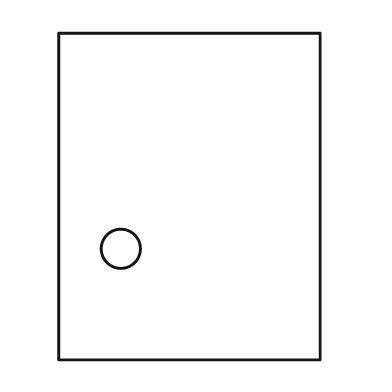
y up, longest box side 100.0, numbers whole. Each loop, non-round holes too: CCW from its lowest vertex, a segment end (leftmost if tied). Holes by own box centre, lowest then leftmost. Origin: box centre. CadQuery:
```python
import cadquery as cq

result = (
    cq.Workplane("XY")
    .moveTo(-40.0, -50.0)
    .lineTo(40.0, -50.0)
    .lineTo(40.0, 50.0)
    .lineTo(-40.0, 50.0)
    .close()
    .moveTo(-21.0, -16.0)
    .circle(6.0)
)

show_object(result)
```